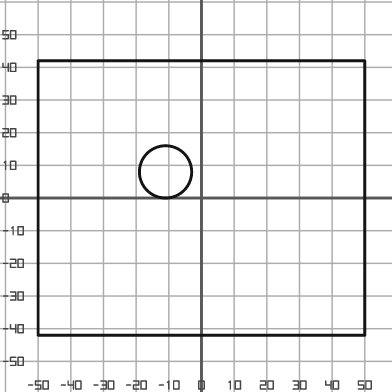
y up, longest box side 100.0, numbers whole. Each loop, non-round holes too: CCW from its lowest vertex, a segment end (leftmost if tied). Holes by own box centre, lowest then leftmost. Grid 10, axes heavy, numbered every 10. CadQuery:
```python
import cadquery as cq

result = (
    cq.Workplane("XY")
    .moveTo(-50.0, -42.0)
    .lineTo(50.0, -42.0)
    .lineTo(50.0, 42.0)
    .lineTo(-50.0, 42.0)
    .close()
    .moveTo(-11.0, 8.0)
    .circle(8.0)
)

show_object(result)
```